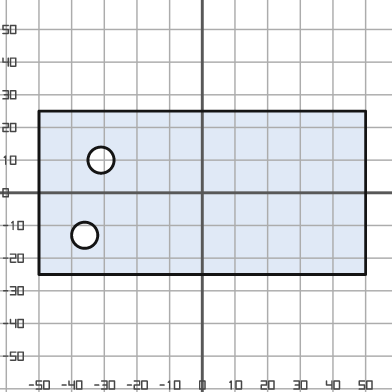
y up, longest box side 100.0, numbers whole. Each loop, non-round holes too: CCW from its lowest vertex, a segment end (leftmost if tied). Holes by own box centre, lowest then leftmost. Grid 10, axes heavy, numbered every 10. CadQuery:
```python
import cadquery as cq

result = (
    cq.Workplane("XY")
    .moveTo(-50.0, -25.0)
    .lineTo(50.0, -25.0)
    .lineTo(50.0, 25.0)
    .lineTo(-50.0, 25.0)
    .close()
    .moveTo(-36.0, -13.0)
    .circle(4.0)
    .moveTo(-31.0, 10.0)
    .circle(4.0)
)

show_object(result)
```